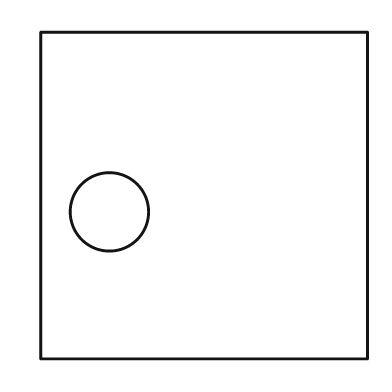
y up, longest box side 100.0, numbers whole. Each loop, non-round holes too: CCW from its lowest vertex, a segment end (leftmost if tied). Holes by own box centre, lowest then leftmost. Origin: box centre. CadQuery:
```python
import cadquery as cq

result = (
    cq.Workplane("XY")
    .moveTo(-50.0, -50.0)
    .lineTo(50.0, -50.0)
    .lineTo(50.0, 50.0)
    .lineTo(-50.0, 50.0)
    .close()
    .moveTo(-29.0, -5.0)
    .circle(12.0)
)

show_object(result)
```